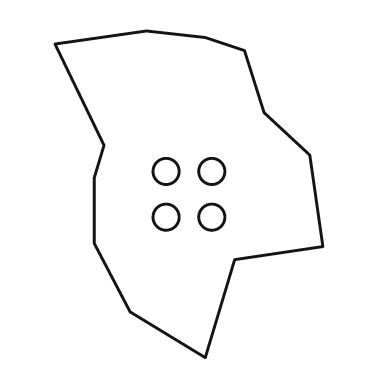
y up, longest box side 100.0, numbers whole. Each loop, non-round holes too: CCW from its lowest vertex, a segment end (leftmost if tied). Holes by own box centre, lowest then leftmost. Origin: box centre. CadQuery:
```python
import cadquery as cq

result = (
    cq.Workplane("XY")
    .moveTo(5.0, -50.0)
    .lineTo(14.0, -20.0)
    .lineTo(41.0, -16.0)
    .lineTo(37.0, 12.0)
    .lineTo(23.0, 25.0)
    .lineTo(17.0, 44.0)
    .lineTo(5.0, 48.0)
    .lineTo(-13.0, 50.0)
    .lineTo(-41.0, 46.0)
    .lineTo(-26.0, 15.0)
    .lineTo(-29.0, 5.0)
    .lineTo(-29.0, -15.0)
    .lineTo(-18.0, -36.0)
    .close()
    .moveTo(-7.0, -7.0)
    .circle(4.0)
    .moveTo(7.0, -7.0)
    .circle(4.0)
    .moveTo(-7.0, 7.0)
    .circle(4.0)
    .moveTo(7.0, 7.0)
    .circle(4.0)
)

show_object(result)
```